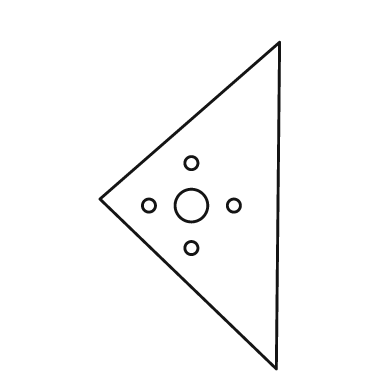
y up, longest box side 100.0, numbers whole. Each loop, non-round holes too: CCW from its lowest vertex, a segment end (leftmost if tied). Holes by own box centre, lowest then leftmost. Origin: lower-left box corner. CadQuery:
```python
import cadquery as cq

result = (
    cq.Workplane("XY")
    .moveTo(54.0, 0.0)
    .lineTo(55.0, 100.0)
    .lineTo(0.0, 52.0)
    .close()
    .moveTo(28.0, 37.0)
    .circle(2.0)
    .moveTo(15.0, 50.0)
    .circle(2.0)
    .moveTo(28.0, 50.0)
    .circle(5.0)
    .moveTo(41.0, 50.0)
    .circle(2.0)
    .moveTo(28.0, 63.0)
    .circle(2.0)
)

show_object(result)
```